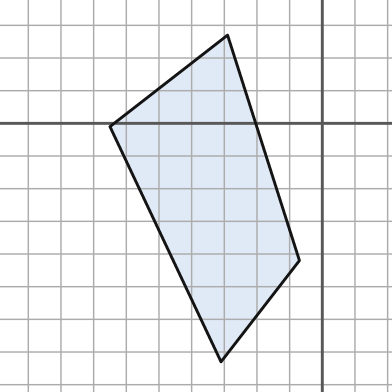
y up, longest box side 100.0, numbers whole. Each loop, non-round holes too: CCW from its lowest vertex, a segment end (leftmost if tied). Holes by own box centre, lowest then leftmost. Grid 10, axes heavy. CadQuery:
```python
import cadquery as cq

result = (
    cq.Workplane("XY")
    .moveTo(-31.0, -73.0)
    .lineTo(-7.0, -42.0)
    .lineTo(-29.0, 27.0)
    .lineTo(-65.0, -1.0)
    .close()
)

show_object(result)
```